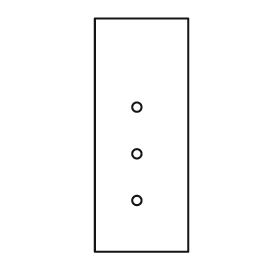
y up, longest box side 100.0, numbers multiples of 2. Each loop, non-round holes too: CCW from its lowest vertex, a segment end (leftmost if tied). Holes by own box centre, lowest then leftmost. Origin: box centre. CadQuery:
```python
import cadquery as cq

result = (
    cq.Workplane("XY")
    .moveTo(-20.0, -50.0)
    .lineTo(20.0, -50.0)
    .lineTo(20.0, 50.0)
    .lineTo(-20.0, 50.0)
    .close()
    .moveTo(-2.0, -28.0)
    .circle(2.0)
    .moveTo(-2.0, -8.0)
    .circle(2.0)
    .moveTo(-2.0, 12.0)
    .circle(2.0)
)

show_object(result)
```